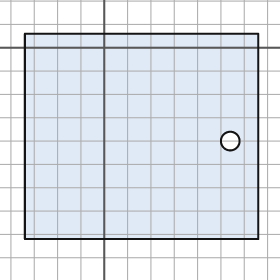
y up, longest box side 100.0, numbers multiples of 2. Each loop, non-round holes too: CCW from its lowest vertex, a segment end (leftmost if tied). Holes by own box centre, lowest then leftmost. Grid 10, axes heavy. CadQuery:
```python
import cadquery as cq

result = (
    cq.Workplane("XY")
    .moveTo(-34.0, -82.0)
    .lineTo(66.0, -82.0)
    .lineTo(66.0, 6.0)
    .lineTo(-34.0, 6.0)
    .close()
    .moveTo(54.0, -40.0)
    .circle(4.0)
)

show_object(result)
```